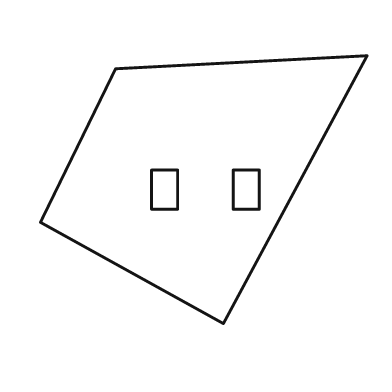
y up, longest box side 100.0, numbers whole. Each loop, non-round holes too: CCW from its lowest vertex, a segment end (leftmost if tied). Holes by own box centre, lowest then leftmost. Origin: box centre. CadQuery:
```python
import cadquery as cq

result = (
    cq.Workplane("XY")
    .moveTo(6.0, -41.0)
    .lineTo(50.0, 41.0)
    .lineTo(-27.0, 37.0)
    .lineTo(-50.0, -10.0)
    .close()
    .moveTo(-16.0, -6.0)
    .lineTo(-8.0, -6.0)
    .lineTo(-8.0, 6.0)
    .lineTo(-16.0, 6.0)
    .close()
    .moveTo(9.0, -6.0)
    .lineTo(17.0, -6.0)
    .lineTo(17.0, 6.0)
    .lineTo(9.0, 6.0)
    .close()
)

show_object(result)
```